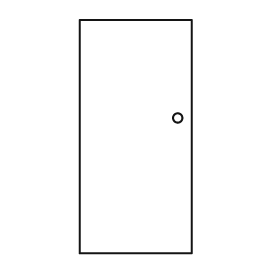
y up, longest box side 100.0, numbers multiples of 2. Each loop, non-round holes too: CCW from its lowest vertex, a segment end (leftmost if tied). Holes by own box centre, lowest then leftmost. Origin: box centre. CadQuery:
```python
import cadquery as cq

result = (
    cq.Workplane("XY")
    .moveTo(-24.0, -50.0)
    .lineTo(24.0, -50.0)
    .lineTo(24.0, 50.0)
    .lineTo(-24.0, 50.0)
    .close()
    .moveTo(18.0, 8.0)
    .circle(2.0)
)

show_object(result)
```